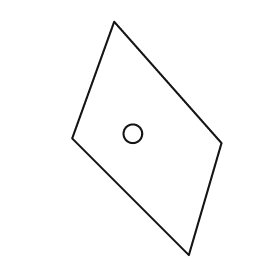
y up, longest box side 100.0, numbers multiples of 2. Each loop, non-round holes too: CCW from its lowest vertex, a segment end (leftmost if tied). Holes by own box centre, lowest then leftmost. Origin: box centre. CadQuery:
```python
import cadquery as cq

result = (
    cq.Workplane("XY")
    .moveTo(18.0, -50.0)
    .lineTo(32.0, -2.0)
    .lineTo(-14.0, 50.0)
    .lineTo(-32.0, 0.0)
    .close()
    .moveTo(-6.0, 2.0)
    .circle(4.0)
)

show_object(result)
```